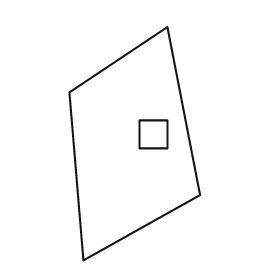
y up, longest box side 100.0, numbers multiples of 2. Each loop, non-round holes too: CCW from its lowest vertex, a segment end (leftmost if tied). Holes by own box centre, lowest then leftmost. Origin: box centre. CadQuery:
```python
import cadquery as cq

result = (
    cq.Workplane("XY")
    .moveTo(-22.0, -50.0)
    .lineTo(28.0, -22.0)
    .lineTo(14.0, 50.0)
    .lineTo(-28.0, 22.0)
    .close()
    .moveTo(2.0, -2.0)
    .lineTo(14.0, -2.0)
    .lineTo(14.0, 10.0)
    .lineTo(2.0, 10.0)
    .close()
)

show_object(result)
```